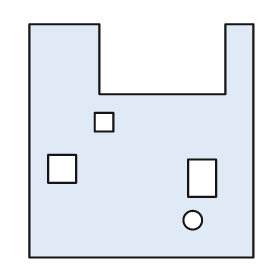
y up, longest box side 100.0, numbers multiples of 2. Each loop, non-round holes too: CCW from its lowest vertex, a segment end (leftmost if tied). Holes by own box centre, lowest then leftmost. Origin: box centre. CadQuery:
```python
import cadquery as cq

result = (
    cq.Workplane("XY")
    .moveTo(-48.0, -50.0)
    .lineTo(48.0, -50.0)
    .lineTo(48.0, 50.0)
    .lineTo(36.0, 50.0)
    .lineTo(36.0, 20.0)
    .lineTo(-18.0, 20.0)
    .lineTo(-18.0, 50.0)
    .lineTo(-48.0, 50.0)
    .close()
    .moveTo(22.0, -34.0)
    .circle(4.0)
    .moveTo(20.0, -24.0)
    .lineTo(32.0, -24.0)
    .lineTo(32.0, -8.0)
    .lineTo(20.0, -8.0)
    .close()
    .moveTo(-40.0, -18.0)
    .lineTo(-28.0, -18.0)
    .lineTo(-28.0, -6.0)
    .lineTo(-40.0, -6.0)
    .close()
    .moveTo(-20.0, 4.0)
    .lineTo(-12.0, 4.0)
    .lineTo(-12.0, 12.0)
    .lineTo(-20.0, 12.0)
    .close()
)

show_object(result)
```